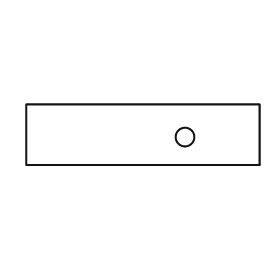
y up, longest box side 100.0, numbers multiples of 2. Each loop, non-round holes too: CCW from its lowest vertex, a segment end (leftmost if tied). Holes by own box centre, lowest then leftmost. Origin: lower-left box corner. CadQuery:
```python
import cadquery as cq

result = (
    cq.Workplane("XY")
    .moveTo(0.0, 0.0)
    .lineTo(100.0, 0.0)
    .lineTo(100.0, 26.0)
    .lineTo(0.0, 26.0)
    .close()
    .moveTo(68.0, 12.0)
    .circle(4.0)
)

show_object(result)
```